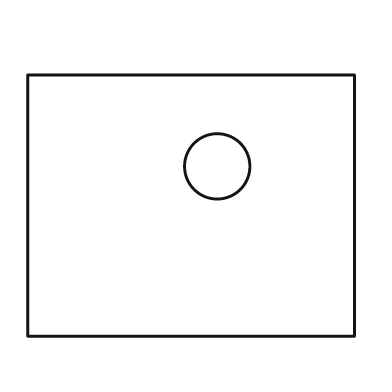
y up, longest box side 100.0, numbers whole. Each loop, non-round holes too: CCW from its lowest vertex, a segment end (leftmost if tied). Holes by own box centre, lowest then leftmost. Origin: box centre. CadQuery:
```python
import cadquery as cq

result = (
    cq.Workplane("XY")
    .moveTo(-50.0, -40.0)
    .lineTo(50.0, -40.0)
    .lineTo(50.0, 40.0)
    .lineTo(-50.0, 40.0)
    .close()
    .moveTo(8.0, 12.0)
    .circle(10.0)
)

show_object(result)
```